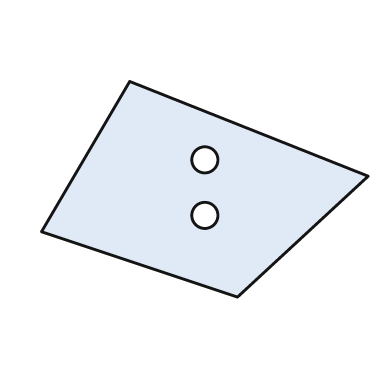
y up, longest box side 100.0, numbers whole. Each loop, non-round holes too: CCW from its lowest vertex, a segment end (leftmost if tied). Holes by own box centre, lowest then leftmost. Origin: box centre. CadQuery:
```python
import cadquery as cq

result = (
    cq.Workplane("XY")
    .moveTo(10.0, -33.0)
    .lineTo(50.0, 4.0)
    .lineTo(-23.0, 33.0)
    .lineTo(-50.0, -13.0)
    .close()
    .moveTo(0.0, -8.0)
    .circle(4.0)
    .moveTo(0.0, 9.0)
    .circle(4.0)
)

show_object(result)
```